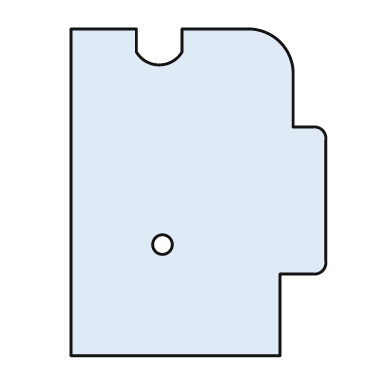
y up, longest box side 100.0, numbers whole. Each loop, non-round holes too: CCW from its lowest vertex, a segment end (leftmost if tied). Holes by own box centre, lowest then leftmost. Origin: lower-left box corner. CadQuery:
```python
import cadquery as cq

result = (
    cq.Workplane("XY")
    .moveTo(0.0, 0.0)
    .lineTo(64.0, 0.0)
    .lineTo(64.0, 25.0)
    .lineTo(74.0, 25.0)
    .threePointArc((77.0, 26.0), (78.0, 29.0))
    .lineTo(78.0, 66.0)
    .threePointArc((77.0, 69.0), (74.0, 70.0))
    .lineTo(68.0, 70.0)
    .lineTo(68.0, 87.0)
    .threePointArc((64.0, 96.0), (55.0, 100.0))
    .lineTo(34.0, 100.0)
    .lineTo(34.0, 93.0)
    .threePointArc((27.0, 89.0), (20.0, 93.0))
    .lineTo(20.0, 100.0)
    .lineTo(0.0, 100.0)
    .close()
    .moveTo(28.0, 34.0)
    .circle(3.0)
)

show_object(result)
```